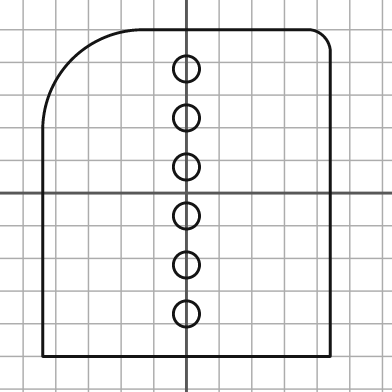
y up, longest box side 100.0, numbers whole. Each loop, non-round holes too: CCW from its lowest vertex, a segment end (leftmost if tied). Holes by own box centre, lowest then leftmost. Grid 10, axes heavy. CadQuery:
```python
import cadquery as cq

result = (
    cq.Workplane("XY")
    .moveTo(-44.0, -50.0)
    .lineTo(44.0, -50.0)
    .lineTo(44.0, 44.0)
    .threePointArc((42.0, 48.0), (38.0, 50.0))
    .lineTo(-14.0, 50.0)
    .threePointArc((-35.0, 41.0), (-44.0, 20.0))
    .close()
    .moveTo(0.0, -37.0)
    .circle(4.0)
    .moveTo(0.0, -22.0)
    .circle(4.0)
    .moveTo(0.0, -7.0)
    .circle(4.0)
    .moveTo(0.0, 8.0)
    .circle(4.0)
    .moveTo(0.0, 23.0)
    .circle(4.0)
    .moveTo(0.0, 38.0)
    .circle(4.0)
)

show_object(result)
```